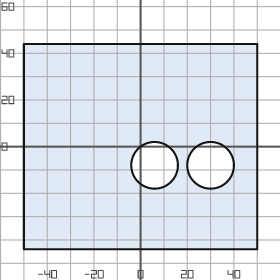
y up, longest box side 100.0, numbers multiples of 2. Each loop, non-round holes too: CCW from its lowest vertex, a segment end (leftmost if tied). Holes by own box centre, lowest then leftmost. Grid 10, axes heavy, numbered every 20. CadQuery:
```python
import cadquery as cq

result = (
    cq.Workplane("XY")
    .moveTo(-50.0, -44.0)
    .lineTo(50.0, -44.0)
    .lineTo(50.0, 44.0)
    .lineTo(-50.0, 44.0)
    .close()
    .moveTo(6.0, -8.0)
    .circle(10.0)
    .moveTo(30.0, -8.0)
    .circle(10.0)
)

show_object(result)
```